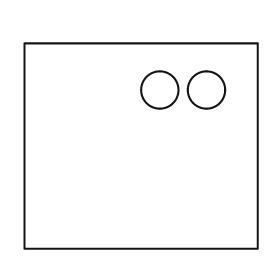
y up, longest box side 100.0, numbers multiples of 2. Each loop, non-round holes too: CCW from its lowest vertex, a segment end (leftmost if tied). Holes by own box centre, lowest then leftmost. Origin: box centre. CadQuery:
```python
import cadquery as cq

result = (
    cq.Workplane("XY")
    .moveTo(-50.0, -44.0)
    .lineTo(50.0, -44.0)
    .lineTo(50.0, 44.0)
    .lineTo(-50.0, 44.0)
    .close()
    .moveTo(8.0, 24.0)
    .circle(8.0)
    .moveTo(28.0, 24.0)
    .circle(8.0)
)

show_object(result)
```